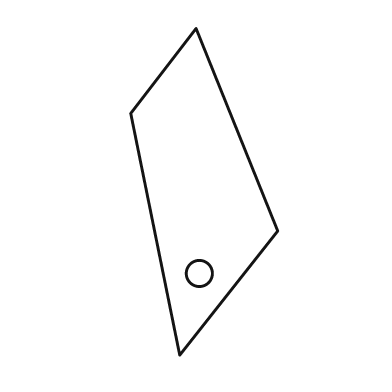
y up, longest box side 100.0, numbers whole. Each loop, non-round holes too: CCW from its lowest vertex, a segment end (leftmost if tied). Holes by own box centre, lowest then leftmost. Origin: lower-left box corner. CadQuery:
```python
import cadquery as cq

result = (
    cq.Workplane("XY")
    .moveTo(15.0, 0.0)
    .lineTo(45.0, 38.0)
    .lineTo(20.0, 100.0)
    .lineTo(0.0, 74.0)
    .close()
    .moveTo(21.0, 25.0)
    .circle(4.0)
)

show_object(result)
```